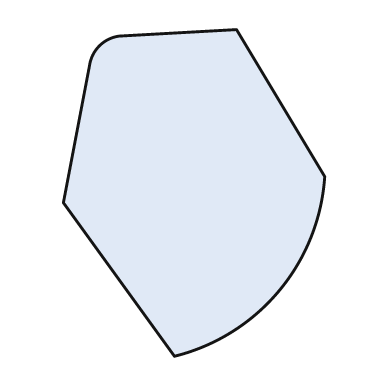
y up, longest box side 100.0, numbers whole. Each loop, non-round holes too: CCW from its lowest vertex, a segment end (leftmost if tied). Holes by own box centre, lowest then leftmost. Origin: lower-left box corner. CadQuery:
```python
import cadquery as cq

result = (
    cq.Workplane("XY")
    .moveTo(34.0, 0.0)
    .threePointArc((66.0, 20.0), (80.0, 55.0))
    .lineTo(53.0, 100.0)
    .lineTo(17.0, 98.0)
    .threePointArc((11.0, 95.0), (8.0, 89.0))
    .lineTo(0.0, 47.0)
    .close()
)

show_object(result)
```